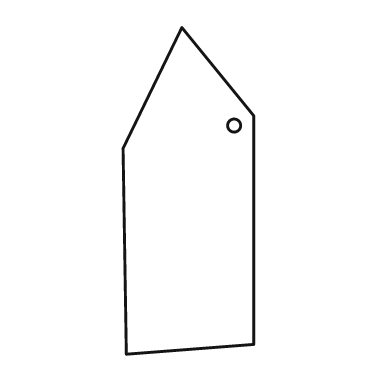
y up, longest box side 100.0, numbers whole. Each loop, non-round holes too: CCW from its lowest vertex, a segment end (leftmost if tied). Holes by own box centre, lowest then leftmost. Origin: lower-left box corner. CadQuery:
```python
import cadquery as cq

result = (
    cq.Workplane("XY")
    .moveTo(1.0, 0.0)
    .lineTo(40.0, 3.0)
    .lineTo(40.0, 73.0)
    .lineTo(18.0, 100.0)
    .lineTo(0.0, 63.0)
    .close()
    .moveTo(34.0, 70.0)
    .circle(2.0)
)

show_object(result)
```